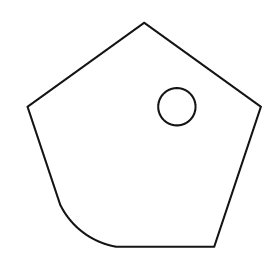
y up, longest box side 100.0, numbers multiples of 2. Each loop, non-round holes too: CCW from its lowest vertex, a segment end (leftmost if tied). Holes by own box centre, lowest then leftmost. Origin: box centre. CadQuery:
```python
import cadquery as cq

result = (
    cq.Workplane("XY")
    .moveTo(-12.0, -48.0)
    .lineTo(30.0, -48.0)
    .lineTo(50.0, 12.0)
    .lineTo(0.0, 48.0)
    .lineTo(-50.0, 12.0)
    .lineTo(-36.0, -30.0)
    .threePointArc((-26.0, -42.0), (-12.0, -48.0))
    .close()
    .moveTo(14.0, 12.0)
    .circle(8.0)
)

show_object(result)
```